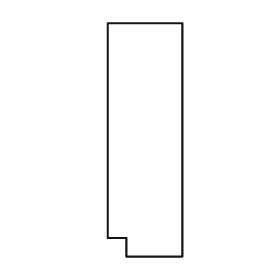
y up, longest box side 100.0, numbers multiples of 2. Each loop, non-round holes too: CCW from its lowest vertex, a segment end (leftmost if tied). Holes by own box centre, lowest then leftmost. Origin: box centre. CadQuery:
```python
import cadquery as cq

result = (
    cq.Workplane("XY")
    .moveTo(-8.0, -50.0)
    .lineTo(16.0, -50.0)
    .lineTo(16.0, 50.0)
    .lineTo(-16.0, 50.0)
    .lineTo(-16.0, -42.0)
    .lineTo(-8.0, -42.0)
    .close()
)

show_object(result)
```